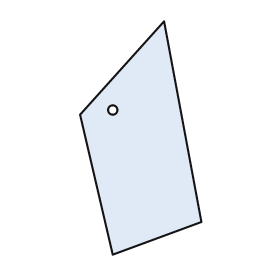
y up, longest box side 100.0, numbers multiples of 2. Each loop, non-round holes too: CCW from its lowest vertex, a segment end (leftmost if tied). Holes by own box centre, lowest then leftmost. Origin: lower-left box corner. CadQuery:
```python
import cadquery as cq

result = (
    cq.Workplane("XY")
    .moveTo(14.0, 0.0)
    .lineTo(52.0, 14.0)
    .lineTo(36.0, 100.0)
    .lineTo(0.0, 60.0)
    .close()
    .moveTo(14.0, 62.0)
    .circle(2.0)
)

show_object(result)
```